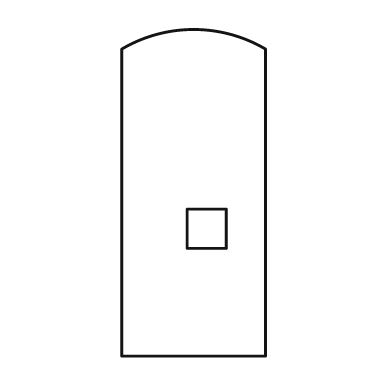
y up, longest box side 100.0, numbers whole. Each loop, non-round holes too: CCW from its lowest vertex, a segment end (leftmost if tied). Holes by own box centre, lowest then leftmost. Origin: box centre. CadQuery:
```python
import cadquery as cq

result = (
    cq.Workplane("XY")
    .moveTo(-22.0, -50.0)
    .lineTo(22.0, -50.0)
    .lineTo(22.0, 44.0)
    .threePointArc((0.0, 50.0), (-22.0, 44.0))
    .close()
    .moveTo(-2.0, -17.0)
    .lineTo(10.0, -17.0)
    .lineTo(10.0, -5.0)
    .lineTo(-2.0, -5.0)
    .close()
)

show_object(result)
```